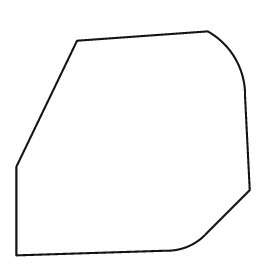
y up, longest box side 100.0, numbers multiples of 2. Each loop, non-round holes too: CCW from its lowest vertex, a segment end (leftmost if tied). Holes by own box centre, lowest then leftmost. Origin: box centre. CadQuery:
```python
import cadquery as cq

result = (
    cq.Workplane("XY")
    .moveTo(-50.0, -48.0)
    .lineTo(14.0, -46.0)
    .threePointArc((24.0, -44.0), (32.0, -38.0))
    .lineTo(50.0, -20.0)
    .lineTo(48.0, 20.0)
    .threePointArc((44.0, 36.0), (32.0, 48.0))
    .lineTo(-24.0, 44.0)
    .lineTo(-50.0, -10.0)
    .close()
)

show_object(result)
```